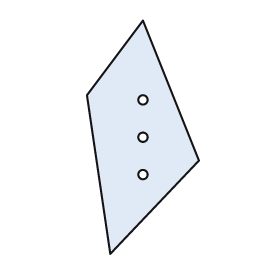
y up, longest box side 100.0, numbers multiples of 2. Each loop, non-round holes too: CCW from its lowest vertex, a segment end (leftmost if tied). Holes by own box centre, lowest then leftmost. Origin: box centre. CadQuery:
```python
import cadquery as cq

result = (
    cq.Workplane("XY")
    .moveTo(-14.0, -50.0)
    .lineTo(24.0, -10.0)
    .lineTo(0.0, 50.0)
    .lineTo(-24.0, 18.0)
    .close()
    .moveTo(0.0, -16.0)
    .circle(2.0)
    .moveTo(0.0, 0.0)
    .circle(2.0)
    .moveTo(0.0, 16.0)
    .circle(2.0)
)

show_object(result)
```